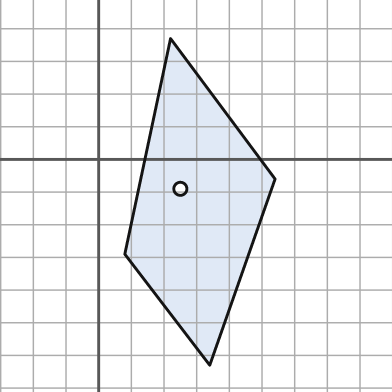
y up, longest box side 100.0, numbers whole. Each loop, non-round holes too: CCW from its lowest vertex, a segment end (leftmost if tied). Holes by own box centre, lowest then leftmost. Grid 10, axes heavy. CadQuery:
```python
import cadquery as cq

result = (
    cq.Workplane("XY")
    .moveTo(34.0, -63.0)
    .lineTo(54.0, -6.0)
    .lineTo(22.0, 37.0)
    .lineTo(8.0, -29.0)
    .close()
    .moveTo(25.0, -9.0)
    .circle(2.0)
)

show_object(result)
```